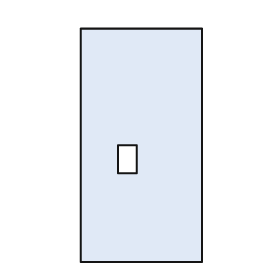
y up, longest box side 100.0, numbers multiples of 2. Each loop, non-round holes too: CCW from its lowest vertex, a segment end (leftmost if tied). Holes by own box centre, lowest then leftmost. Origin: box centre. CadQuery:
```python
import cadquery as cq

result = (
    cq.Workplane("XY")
    .moveTo(-26.0, -50.0)
    .lineTo(26.0, -50.0)
    .lineTo(26.0, 50.0)
    .lineTo(-26.0, 50.0)
    .close()
    .moveTo(-10.0, -12.0)
    .lineTo(-2.0, -12.0)
    .lineTo(-2.0, 0.0)
    .lineTo(-10.0, 0.0)
    .close()
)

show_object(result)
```